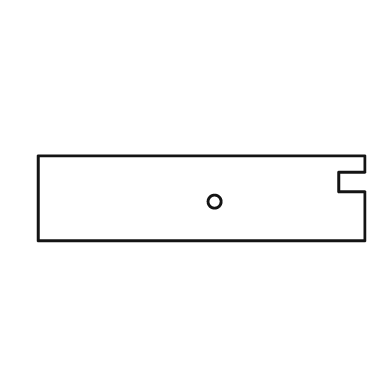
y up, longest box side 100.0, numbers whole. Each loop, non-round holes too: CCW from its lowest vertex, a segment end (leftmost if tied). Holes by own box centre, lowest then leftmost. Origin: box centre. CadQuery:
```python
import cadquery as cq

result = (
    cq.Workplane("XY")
    .moveTo(-50.0, -13.0)
    .lineTo(50.0, -13.0)
    .lineTo(50.0, 2.0)
    .lineTo(42.0, 2.0)
    .lineTo(42.0, 8.0)
    .lineTo(50.0, 8.0)
    .lineTo(50.0, 13.0)
    .lineTo(-50.0, 13.0)
    .close()
    .moveTo(4.0, -1.0)
    .circle(2.0)
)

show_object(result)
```